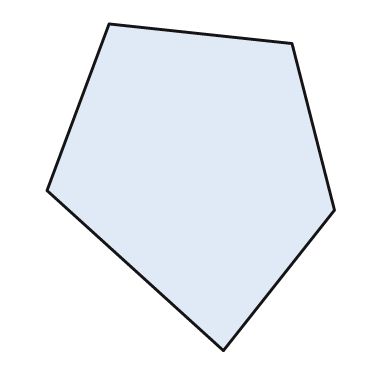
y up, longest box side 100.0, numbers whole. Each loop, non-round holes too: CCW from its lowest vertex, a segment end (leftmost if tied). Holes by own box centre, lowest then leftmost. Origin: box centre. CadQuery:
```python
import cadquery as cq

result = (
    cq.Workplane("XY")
    .moveTo(10.0, -50.0)
    .lineTo(44.0, -7.0)
    .lineTo(31.0, 44.0)
    .lineTo(-25.0, 50.0)
    .lineTo(-44.0, -1.0)
    .close()
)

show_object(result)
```